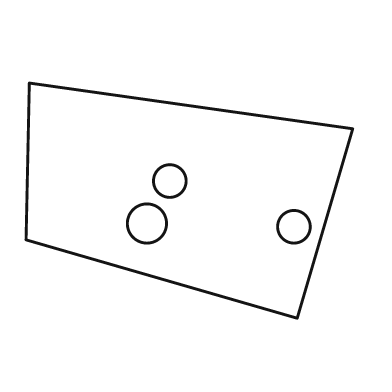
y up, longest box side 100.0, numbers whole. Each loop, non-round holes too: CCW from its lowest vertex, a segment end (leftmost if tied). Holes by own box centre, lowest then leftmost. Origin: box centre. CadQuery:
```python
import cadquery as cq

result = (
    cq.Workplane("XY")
    .moveTo(33.0, -36.0)
    .lineTo(50.0, 22.0)
    .lineTo(-49.0, 36.0)
    .lineTo(-50.0, -12.0)
    .close()
    .moveTo(32.0, -8.0)
    .circle(5.0)
    .moveTo(-13.0, -7.0)
    .circle(6.0)
    .moveTo(-6.0, 6.0)
    .circle(5.0)
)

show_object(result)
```